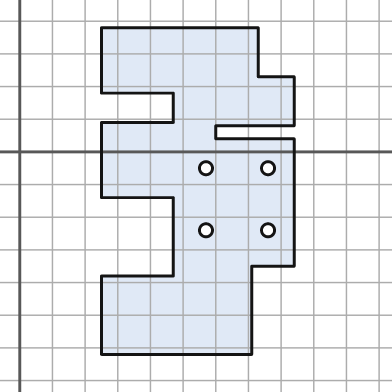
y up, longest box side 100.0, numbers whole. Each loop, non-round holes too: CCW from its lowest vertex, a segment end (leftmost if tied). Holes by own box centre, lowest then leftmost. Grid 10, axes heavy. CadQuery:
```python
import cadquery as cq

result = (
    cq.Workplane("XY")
    .moveTo(25.0, -62.0)
    .lineTo(71.0, -62.0)
    .lineTo(71.0, -35.0)
    .lineTo(84.0, -35.0)
    .lineTo(84.0, 4.0)
    .lineTo(60.0, 4.0)
    .lineTo(60.0, 8.0)
    .lineTo(84.0, 8.0)
    .lineTo(84.0, 23.0)
    .lineTo(73.0, 23.0)
    .lineTo(73.0, 38.0)
    .lineTo(25.0, 38.0)
    .lineTo(25.0, 18.0)
    .lineTo(47.0, 18.0)
    .lineTo(47.0, 9.0)
    .lineTo(25.0, 9.0)
    .lineTo(25.0, -14.0)
    .lineTo(47.0, -14.0)
    .lineTo(47.0, -38.0)
    .lineTo(25.0, -38.0)
    .close()
    .moveTo(57.0, -24.0)
    .circle(2.0)
    .moveTo(76.0, -24.0)
    .circle(2.0)
    .moveTo(57.0, -5.0)
    .circle(2.0)
    .moveTo(76.0, -5.0)
    .circle(2.0)
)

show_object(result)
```